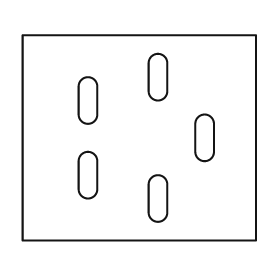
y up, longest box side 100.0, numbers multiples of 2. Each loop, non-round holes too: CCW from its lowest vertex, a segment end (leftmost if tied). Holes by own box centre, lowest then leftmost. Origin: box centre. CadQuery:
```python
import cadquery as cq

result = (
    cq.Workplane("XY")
    .moveTo(-50.0, -44.0)
    .lineTo(50.0, -44.0)
    .lineTo(50.0, 44.0)
    .lineTo(-50.0, 44.0)
    .close()
    .moveTo(4.0, -32.0)
    .threePointArc((8.0, -36.0), (12.0, -32.0))
    .lineTo(12.0, -20.0)
    .threePointArc((8.0, -16.0), (4.0, -20.0))
    .close()
    .moveTo(-26.0, -22.0)
    .threePointArc((-22.0, -26.0), (-18.0, -22.0))
    .lineTo(-18.0, -10.0)
    .threePointArc((-22.0, -6.0), (-26.0, -10.0))
    .close()
    .moveTo(24.0, -6.0)
    .threePointArc((28.0, -10.0), (32.0, -6.0))
    .lineTo(32.0, 6.0)
    .threePointArc((28.0, 10.0), (24.0, 6.0))
    .close()
    .moveTo(-26.0, 10.0)
    .threePointArc((-22.0, 6.0), (-18.0, 10.0))
    .lineTo(-18.0, 22.0)
    .threePointArc((-22.0, 26.0), (-26.0, 22.0))
    .close()
    .moveTo(4.0, 20.0)
    .threePointArc((8.0, 16.0), (12.0, 20.0))
    .lineTo(12.0, 32.0)
    .threePointArc((8.0, 36.0), (4.0, 32.0))
    .close()
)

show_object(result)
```